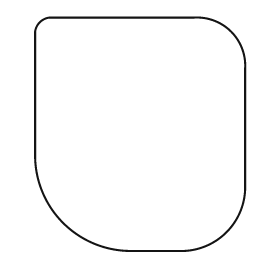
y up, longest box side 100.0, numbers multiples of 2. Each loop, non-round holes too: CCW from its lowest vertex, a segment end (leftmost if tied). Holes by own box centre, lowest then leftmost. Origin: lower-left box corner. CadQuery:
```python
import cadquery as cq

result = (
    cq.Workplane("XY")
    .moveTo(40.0, 0.0)
    .lineTo(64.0, 0.0)
    .threePointArc((82.0, 8.0), (90.0, 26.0))
    .lineTo(90.0, 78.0)
    .threePointArc((84.0, 94.0), (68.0, 100.0))
    .lineTo(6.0, 100.0)
    .threePointArc((2.0, 98.0), (0.0, 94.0))
    .lineTo(0.0, 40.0)
    .threePointArc((12.0, 12.0), (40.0, 0.0))
    .close()
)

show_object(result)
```